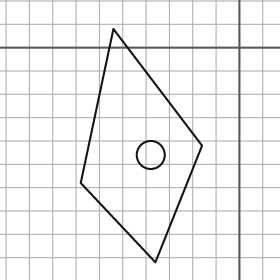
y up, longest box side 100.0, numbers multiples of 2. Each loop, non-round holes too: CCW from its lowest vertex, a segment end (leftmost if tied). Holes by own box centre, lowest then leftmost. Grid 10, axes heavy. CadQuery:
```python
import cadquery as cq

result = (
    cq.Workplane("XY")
    .moveTo(-36.0, -92.0)
    .lineTo(-16.0, -42.0)
    .lineTo(-54.0, 8.0)
    .lineTo(-68.0, -58.0)
    .close()
    .moveTo(-38.0, -46.0)
    .circle(6.0)
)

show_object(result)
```